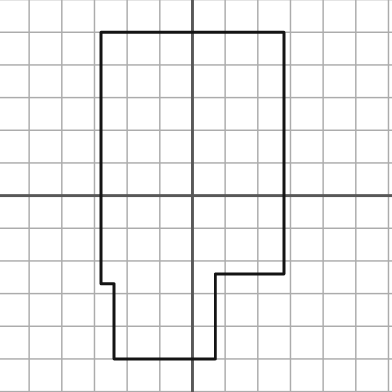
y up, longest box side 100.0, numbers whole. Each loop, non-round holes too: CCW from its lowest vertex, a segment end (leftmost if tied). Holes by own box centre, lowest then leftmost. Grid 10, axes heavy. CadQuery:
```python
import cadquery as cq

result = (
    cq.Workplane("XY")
    .moveTo(-24.0, -50.0)
    .lineTo(7.0, -50.0)
    .lineTo(7.0, -24.0)
    .lineTo(28.0, -24.0)
    .lineTo(28.0, 50.0)
    .lineTo(-28.0, 50.0)
    .lineTo(-28.0, -27.0)
    .lineTo(-24.0, -27.0)
    .close()
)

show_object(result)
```